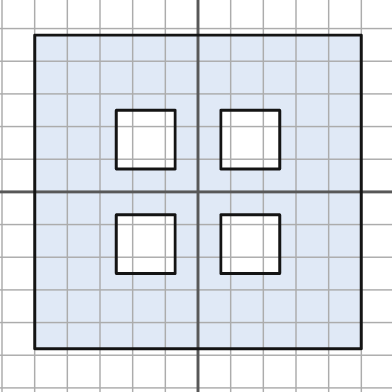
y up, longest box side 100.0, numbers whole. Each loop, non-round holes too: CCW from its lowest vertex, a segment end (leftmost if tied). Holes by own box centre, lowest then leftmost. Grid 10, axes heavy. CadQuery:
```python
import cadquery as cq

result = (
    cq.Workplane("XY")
    .moveTo(-50.0, -48.0)
    .lineTo(50.0, -48.0)
    .lineTo(50.0, 48.0)
    .lineTo(-50.0, 48.0)
    .close()
    .moveTo(-25.0, -25.0)
    .lineTo(-7.0, -25.0)
    .lineTo(-7.0, -7.0)
    .lineTo(-25.0, -7.0)
    .close()
    .moveTo(7.0, -25.0)
    .lineTo(25.0, -25.0)
    .lineTo(25.0, -7.0)
    .lineTo(7.0, -7.0)
    .close()
    .moveTo(-25.0, 7.0)
    .lineTo(-7.0, 7.0)
    .lineTo(-7.0, 25.0)
    .lineTo(-25.0, 25.0)
    .close()
    .moveTo(7.0, 7.0)
    .lineTo(25.0, 7.0)
    .lineTo(25.0, 25.0)
    .lineTo(7.0, 25.0)
    .close()
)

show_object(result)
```